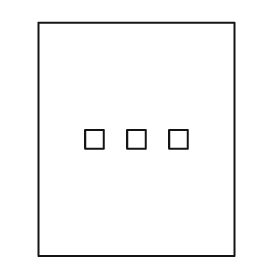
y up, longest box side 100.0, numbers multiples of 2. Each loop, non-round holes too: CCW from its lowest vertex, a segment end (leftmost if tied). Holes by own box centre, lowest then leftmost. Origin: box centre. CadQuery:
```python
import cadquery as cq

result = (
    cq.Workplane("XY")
    .moveTo(-42.0, -50.0)
    .lineTo(42.0, -50.0)
    .lineTo(42.0, 50.0)
    .lineTo(-42.0, 50.0)
    .close()
    .moveTo(-22.0, -4.0)
    .lineTo(-14.0, -4.0)
    .lineTo(-14.0, 4.0)
    .lineTo(-22.0, 4.0)
    .close()
    .moveTo(-4.0, -4.0)
    .lineTo(4.0, -4.0)
    .lineTo(4.0, 4.0)
    .lineTo(-4.0, 4.0)
    .close()
    .moveTo(14.0, -4.0)
    .lineTo(22.0, -4.0)
    .lineTo(22.0, 4.0)
    .lineTo(14.0, 4.0)
    .close()
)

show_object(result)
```